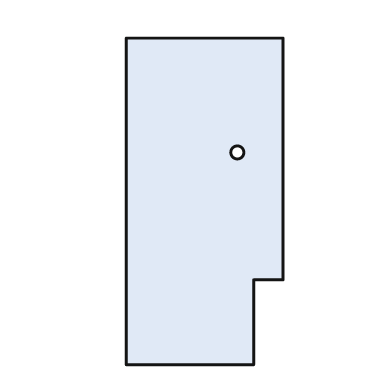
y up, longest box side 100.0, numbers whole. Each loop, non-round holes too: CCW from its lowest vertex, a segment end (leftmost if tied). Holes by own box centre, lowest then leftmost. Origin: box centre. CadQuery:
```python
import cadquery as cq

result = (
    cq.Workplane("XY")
    .moveTo(-24.0, -50.0)
    .lineTo(15.0, -50.0)
    .lineTo(15.0, -24.0)
    .lineTo(24.0, -24.0)
    .lineTo(24.0, 50.0)
    .lineTo(-24.0, 50.0)
    .close()
    .moveTo(10.0, 15.0)
    .circle(2.0)
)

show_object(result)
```